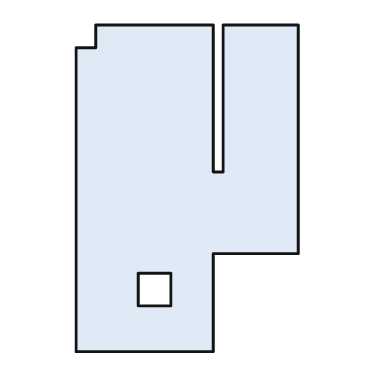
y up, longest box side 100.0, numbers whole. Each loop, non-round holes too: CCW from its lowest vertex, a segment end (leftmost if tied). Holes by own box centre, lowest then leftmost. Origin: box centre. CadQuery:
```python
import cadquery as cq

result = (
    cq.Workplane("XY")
    .moveTo(-34.0, -50.0)
    .lineTo(8.0, -50.0)
    .lineTo(8.0, -20.0)
    .lineTo(34.0, -20.0)
    .lineTo(34.0, 50.0)
    .lineTo(11.0, 50.0)
    .lineTo(11.0, 5.0)
    .lineTo(8.0, 5.0)
    .lineTo(8.0, 50.0)
    .lineTo(-28.0, 50.0)
    .lineTo(-28.0, 43.0)
    .lineTo(-34.0, 43.0)
    .close()
    .moveTo(-15.0, -36.0)
    .lineTo(-5.0, -36.0)
    .lineTo(-5.0, -26.0)
    .lineTo(-15.0, -26.0)
    .close()
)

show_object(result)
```